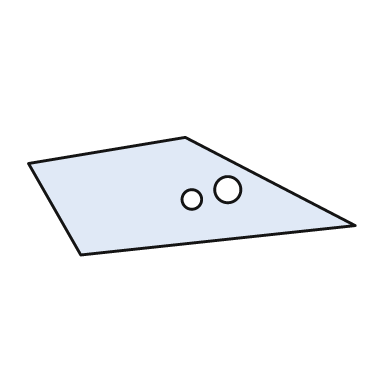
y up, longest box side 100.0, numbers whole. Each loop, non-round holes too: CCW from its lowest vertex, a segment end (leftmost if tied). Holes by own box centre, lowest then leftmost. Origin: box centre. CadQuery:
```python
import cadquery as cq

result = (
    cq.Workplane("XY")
    .moveTo(-34.0, -18.0)
    .lineTo(50.0, -9.0)
    .lineTo(-2.0, 18.0)
    .lineTo(-50.0, 10.0)
    .close()
    .moveTo(0.0, -1.0)
    .circle(3.0)
    .moveTo(11.0, 2.0)
    .circle(4.0)
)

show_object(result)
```